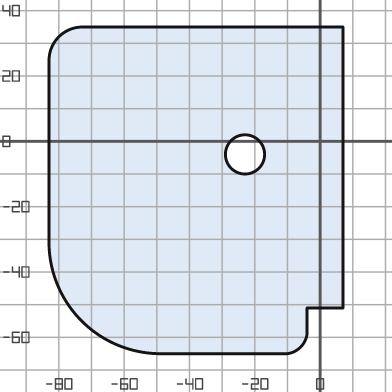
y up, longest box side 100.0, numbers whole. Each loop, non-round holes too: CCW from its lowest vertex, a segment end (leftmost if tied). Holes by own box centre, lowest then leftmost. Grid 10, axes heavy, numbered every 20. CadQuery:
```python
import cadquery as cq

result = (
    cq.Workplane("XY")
    .moveTo(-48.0, -65.0)
    .lineTo(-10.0, -65.0)
    .threePointArc((-6.0, -63.0), (-4.0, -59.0))
    .lineTo(-4.0, -51.0)
    .lineTo(7.0, -51.0)
    .lineTo(7.0, 35.0)
    .lineTo(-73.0, 35.0)
    .threePointArc((-80.0, 32.0), (-83.0, 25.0))
    .lineTo(-83.0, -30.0)
    .threePointArc((-73.0, -55.0), (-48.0, -65.0))
    .close()
    .moveTo(-23.0, -4.0)
    .circle(6.0)
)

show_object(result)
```